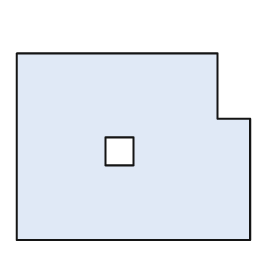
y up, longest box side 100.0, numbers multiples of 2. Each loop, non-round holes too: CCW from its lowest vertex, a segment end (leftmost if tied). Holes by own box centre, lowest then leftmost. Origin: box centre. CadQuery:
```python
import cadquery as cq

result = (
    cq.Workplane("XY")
    .moveTo(-50.0, -40.0)
    .lineTo(50.0, -40.0)
    .lineTo(50.0, 12.0)
    .lineTo(36.0, 12.0)
    .lineTo(36.0, 40.0)
    .lineTo(-50.0, 40.0)
    .close()
    .moveTo(-12.0, -8.0)
    .lineTo(0.0, -8.0)
    .lineTo(0.0, 4.0)
    .lineTo(-12.0, 4.0)
    .close()
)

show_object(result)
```